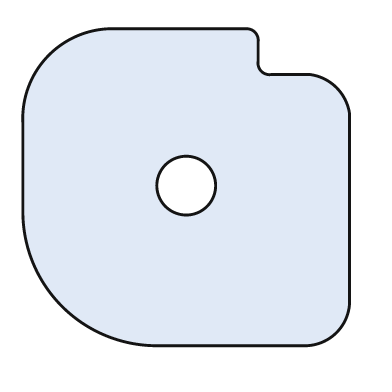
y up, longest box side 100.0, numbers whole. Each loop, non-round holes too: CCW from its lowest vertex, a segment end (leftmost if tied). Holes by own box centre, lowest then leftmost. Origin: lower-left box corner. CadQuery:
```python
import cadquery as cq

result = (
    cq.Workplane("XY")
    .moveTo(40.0, 0.0)
    .lineTo(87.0, 0.0)
    .threePointArc((96.0, 4.0), (100.0, 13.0))
    .lineTo(100.0, 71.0)
    .threePointArc((96.0, 79.0), (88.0, 83.0))
    .lineTo(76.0, 83.0)
    .threePointArc((73.0, 84.0), (72.0, 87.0))
    .lineTo(72.0, 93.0)
    .threePointArc((71.0, 96.0), (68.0, 97.0))
    .lineTo(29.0, 97.0)
    .threePointArc((8.0, 89.0), (0.0, 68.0))
    .lineTo(0.0, 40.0)
    .threePointArc((12.0, 12.0), (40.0, 0.0))
    .close()
    .moveTo(50.0, 49.0)
    .circle(9.0)
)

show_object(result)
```